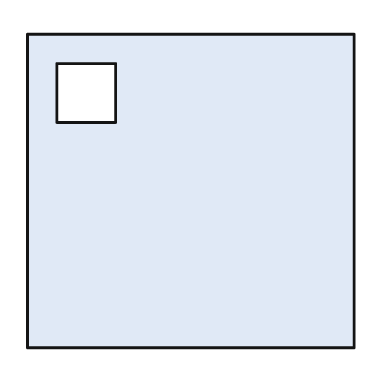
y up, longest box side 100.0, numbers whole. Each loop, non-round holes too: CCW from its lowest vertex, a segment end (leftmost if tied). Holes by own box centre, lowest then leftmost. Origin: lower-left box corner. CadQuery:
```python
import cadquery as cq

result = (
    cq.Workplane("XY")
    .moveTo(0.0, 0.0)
    .lineTo(100.0, 0.0)
    .lineTo(100.0, 96.0)
    .lineTo(0.0, 96.0)
    .close()
    .moveTo(9.0, 69.0)
    .lineTo(27.0, 69.0)
    .lineTo(27.0, 87.0)
    .lineTo(9.0, 87.0)
    .close()
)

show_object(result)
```